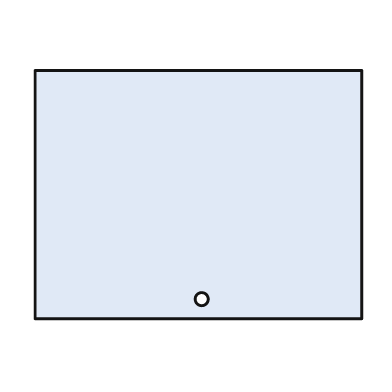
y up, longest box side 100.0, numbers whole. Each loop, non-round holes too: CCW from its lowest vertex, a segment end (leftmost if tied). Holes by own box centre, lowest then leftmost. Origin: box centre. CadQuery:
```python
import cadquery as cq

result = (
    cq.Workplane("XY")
    .moveTo(-50.0, -38.0)
    .lineTo(50.0, -38.0)
    .lineTo(50.0, 38.0)
    .lineTo(-50.0, 38.0)
    .close()
    .moveTo(1.0, -32.0)
    .circle(2.0)
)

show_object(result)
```